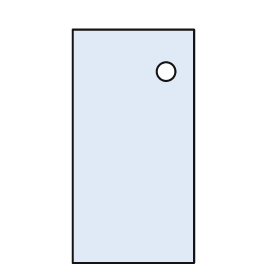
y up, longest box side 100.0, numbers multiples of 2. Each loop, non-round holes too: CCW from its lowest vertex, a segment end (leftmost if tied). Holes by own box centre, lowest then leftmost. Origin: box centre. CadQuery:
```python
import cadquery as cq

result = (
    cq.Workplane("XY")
    .moveTo(-26.0, -50.0)
    .lineTo(26.0, -50.0)
    .lineTo(26.0, 50.0)
    .lineTo(-26.0, 50.0)
    .close()
    .moveTo(14.0, 32.0)
    .circle(4.0)
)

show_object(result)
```